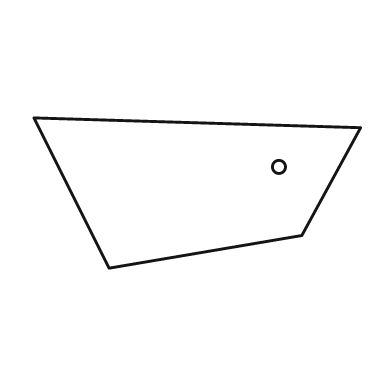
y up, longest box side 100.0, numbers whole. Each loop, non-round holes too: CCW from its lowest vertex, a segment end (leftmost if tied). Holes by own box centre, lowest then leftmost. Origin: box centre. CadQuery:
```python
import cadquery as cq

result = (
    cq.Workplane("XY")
    .moveTo(-27.0, -23.0)
    .lineTo(32.0, -13.0)
    .lineTo(50.0, 20.0)
    .lineTo(-50.0, 23.0)
    .close()
    .moveTo(25.0, 8.0)
    .circle(2.0)
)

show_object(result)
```